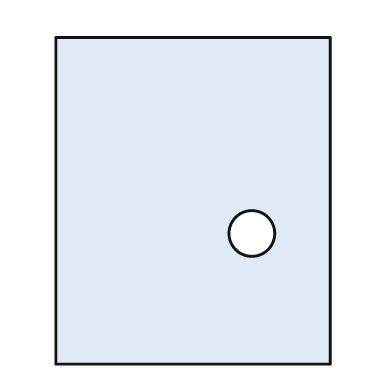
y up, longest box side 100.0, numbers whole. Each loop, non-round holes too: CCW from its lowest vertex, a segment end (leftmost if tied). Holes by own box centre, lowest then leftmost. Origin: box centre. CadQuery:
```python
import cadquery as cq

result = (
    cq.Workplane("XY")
    .moveTo(-42.0, -50.0)
    .lineTo(42.0, -50.0)
    .lineTo(42.0, 50.0)
    .lineTo(-42.0, 50.0)
    .close()
    .moveTo(18.0, -10.0)
    .circle(7.0)
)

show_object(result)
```